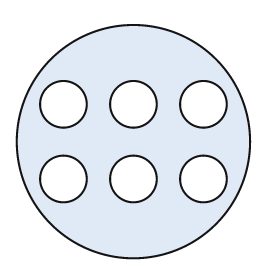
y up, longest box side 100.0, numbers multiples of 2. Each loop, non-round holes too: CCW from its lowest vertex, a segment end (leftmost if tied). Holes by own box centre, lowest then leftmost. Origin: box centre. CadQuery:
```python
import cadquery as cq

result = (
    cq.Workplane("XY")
    .moveTo(0.0, 0.0)
    .circle(50.0)
    .moveTo(-30.0, -16.0)
    .circle(10.0)
    .moveTo(0.0, -16.0)
    .circle(10.0)
    .moveTo(30.0, -16.0)
    .circle(10.0)
    .moveTo(-30.0, 16.0)
    .circle(10.0)
    .moveTo(0.0, 16.0)
    .circle(10.0)
    .moveTo(30.0, 16.0)
    .circle(10.0)
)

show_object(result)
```